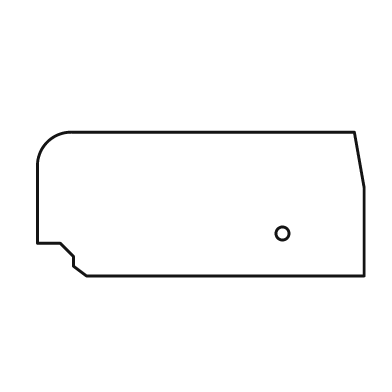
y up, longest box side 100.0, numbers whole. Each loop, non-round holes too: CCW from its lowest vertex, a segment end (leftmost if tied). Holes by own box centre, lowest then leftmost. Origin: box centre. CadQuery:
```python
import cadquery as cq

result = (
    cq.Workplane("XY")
    .moveTo(-35.0, -22.0)
    .lineTo(50.0, -22.0)
    .lineTo(50.0, 5.0)
    .lineTo(47.0, 22.0)
    .lineTo(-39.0, 22.0)
    .threePointArc((-47.0, 19.0), (-50.0, 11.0))
    .lineTo(-50.0, -12.0)
    .lineTo(-43.0, -12.0)
    .lineTo(-39.0, -16.0)
    .lineTo(-39.0, -19.0)
    .close()
    .moveTo(25.0, -9.0)
    .circle(2.0)
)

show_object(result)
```